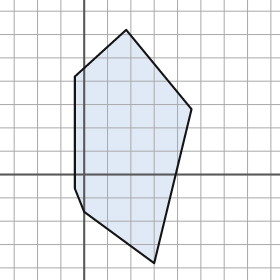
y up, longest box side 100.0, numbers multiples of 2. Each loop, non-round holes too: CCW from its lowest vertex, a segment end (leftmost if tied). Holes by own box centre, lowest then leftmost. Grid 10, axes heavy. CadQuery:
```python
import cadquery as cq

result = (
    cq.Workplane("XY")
    .moveTo(30.0, -38.0)
    .lineTo(46.0, 28.0)
    .lineTo(18.0, 62.0)
    .lineTo(-4.0, 42.0)
    .lineTo(-4.0, -6.0)
    .lineTo(0.0, -16.0)
    .close()
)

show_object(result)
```